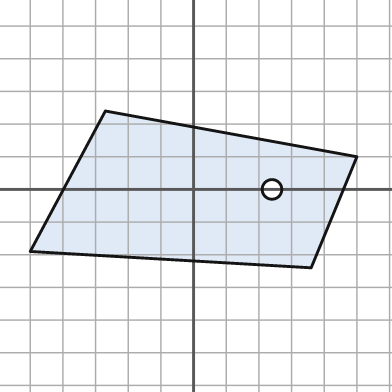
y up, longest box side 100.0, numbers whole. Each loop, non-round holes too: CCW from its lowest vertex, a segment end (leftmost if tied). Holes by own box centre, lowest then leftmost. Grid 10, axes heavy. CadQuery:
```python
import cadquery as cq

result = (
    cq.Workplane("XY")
    .moveTo(36.0, -24.0)
    .lineTo(50.0, 10.0)
    .lineTo(-27.0, 24.0)
    .lineTo(-50.0, -19.0)
    .close()
    .moveTo(24.0, 0.0)
    .circle(3.0)
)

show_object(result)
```